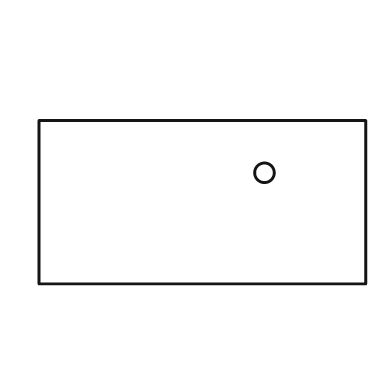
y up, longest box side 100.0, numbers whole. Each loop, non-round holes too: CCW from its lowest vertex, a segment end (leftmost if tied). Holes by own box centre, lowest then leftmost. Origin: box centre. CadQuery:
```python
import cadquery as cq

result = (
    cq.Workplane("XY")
    .moveTo(-50.0, -25.0)
    .lineTo(50.0, -25.0)
    .lineTo(50.0, 25.0)
    .lineTo(-50.0, 25.0)
    .close()
    .moveTo(19.0, 9.0)
    .circle(3.0)
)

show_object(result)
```